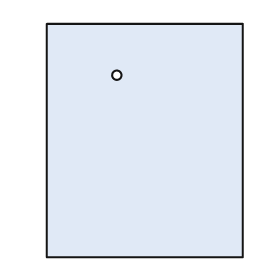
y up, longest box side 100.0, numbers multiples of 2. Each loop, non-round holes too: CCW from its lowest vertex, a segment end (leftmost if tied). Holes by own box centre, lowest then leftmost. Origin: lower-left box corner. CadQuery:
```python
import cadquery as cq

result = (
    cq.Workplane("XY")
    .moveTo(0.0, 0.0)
    .lineTo(84.0, 0.0)
    .lineTo(84.0, 100.0)
    .lineTo(0.0, 100.0)
    .close()
    .moveTo(30.0, 78.0)
    .circle(2.0)
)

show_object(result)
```